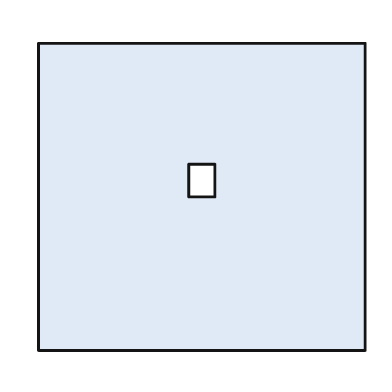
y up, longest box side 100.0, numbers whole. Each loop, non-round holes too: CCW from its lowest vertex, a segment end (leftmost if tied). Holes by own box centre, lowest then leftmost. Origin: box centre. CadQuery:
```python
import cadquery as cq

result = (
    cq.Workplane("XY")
    .moveTo(-50.0, -47.0)
    .lineTo(50.0, -47.0)
    .lineTo(50.0, 47.0)
    .lineTo(-50.0, 47.0)
    .close()
    .moveTo(-4.0, 0.0)
    .lineTo(4.0, 0.0)
    .lineTo(4.0, 10.0)
    .lineTo(-4.0, 10.0)
    .close()
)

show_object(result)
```